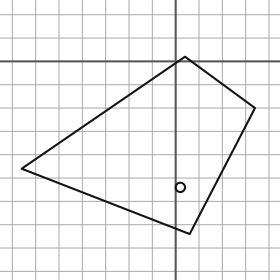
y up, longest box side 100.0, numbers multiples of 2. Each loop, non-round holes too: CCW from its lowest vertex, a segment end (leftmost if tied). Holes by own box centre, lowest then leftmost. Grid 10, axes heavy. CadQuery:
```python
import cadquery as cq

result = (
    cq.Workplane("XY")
    .moveTo(6.0, -74.0)
    .lineTo(34.0, -20.0)
    .lineTo(4.0, 2.0)
    .lineTo(-66.0, -46.0)
    .close()
    .moveTo(2.0, -54.0)
    .circle(2.0)
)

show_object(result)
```